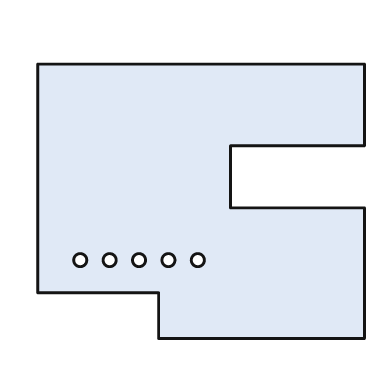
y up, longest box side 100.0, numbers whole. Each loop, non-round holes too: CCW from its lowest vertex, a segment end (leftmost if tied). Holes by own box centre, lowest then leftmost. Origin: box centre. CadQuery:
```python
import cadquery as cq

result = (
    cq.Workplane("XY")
    .moveTo(-13.0, -42.0)
    .lineTo(50.0, -42.0)
    .lineTo(50.0, -2.0)
    .lineTo(9.0, -2.0)
    .lineTo(9.0, 17.0)
    .lineTo(50.0, 17.0)
    .lineTo(50.0, 42.0)
    .lineTo(-50.0, 42.0)
    .lineTo(-50.0, -28.0)
    .lineTo(-13.0, -28.0)
    .close()
    .moveTo(-37.0, -18.0)
    .circle(2.0)
    .moveTo(-28.0, -18.0)
    .circle(2.0)
    .moveTo(-19.0, -18.0)
    .circle(2.0)
    .moveTo(-10.0, -18.0)
    .circle(2.0)
    .moveTo(-1.0, -18.0)
    .circle(2.0)
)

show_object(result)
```